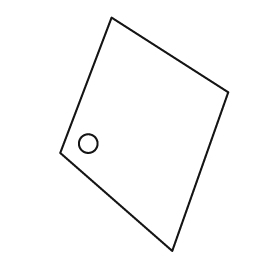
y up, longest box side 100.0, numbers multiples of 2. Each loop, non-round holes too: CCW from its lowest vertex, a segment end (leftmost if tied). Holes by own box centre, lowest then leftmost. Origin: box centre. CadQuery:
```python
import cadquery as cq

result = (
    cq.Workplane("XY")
    .moveTo(12.0, -50.0)
    .lineTo(36.0, 18.0)
    .lineTo(-14.0, 50.0)
    .lineTo(-36.0, -8.0)
    .close()
    .moveTo(-24.0, -4.0)
    .circle(4.0)
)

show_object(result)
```